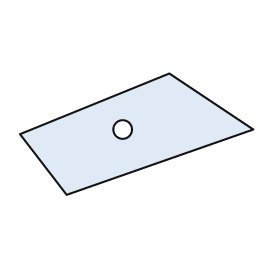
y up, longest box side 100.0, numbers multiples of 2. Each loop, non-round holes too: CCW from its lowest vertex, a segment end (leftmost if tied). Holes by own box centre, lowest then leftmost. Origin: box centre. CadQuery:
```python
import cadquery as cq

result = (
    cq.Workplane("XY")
    .moveTo(-30.0, -26.0)
    .lineTo(50.0, 2.0)
    .lineTo(14.0, 26.0)
    .lineTo(-50.0, 0.0)
    .close()
    .moveTo(-6.0, 2.0)
    .circle(4.0)
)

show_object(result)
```